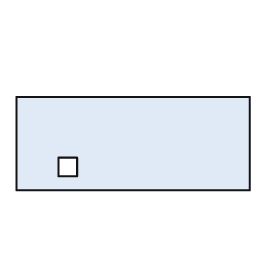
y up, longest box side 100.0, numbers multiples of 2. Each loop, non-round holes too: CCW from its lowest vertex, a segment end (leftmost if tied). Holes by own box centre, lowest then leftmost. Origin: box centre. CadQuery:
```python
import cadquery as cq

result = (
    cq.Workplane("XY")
    .moveTo(-50.0, -20.0)
    .lineTo(50.0, -20.0)
    .lineTo(50.0, 20.0)
    .lineTo(-50.0, 20.0)
    .close()
    .moveTo(-32.0, -14.0)
    .lineTo(-24.0, -14.0)
    .lineTo(-24.0, -6.0)
    .lineTo(-32.0, -6.0)
    .close()
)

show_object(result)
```